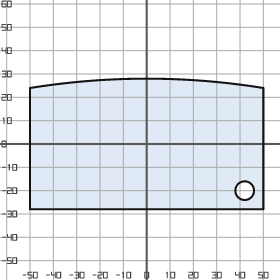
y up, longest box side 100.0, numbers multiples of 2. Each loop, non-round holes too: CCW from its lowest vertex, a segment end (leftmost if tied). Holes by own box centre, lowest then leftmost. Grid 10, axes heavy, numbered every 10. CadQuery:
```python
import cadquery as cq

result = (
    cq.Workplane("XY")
    .moveTo(-50.0, -28.0)
    .lineTo(50.0, -28.0)
    .lineTo(50.0, 24.0)
    .threePointArc((0.0, 28.0), (-50.0, 24.0))
    .close()
    .moveTo(42.0, -20.0)
    .circle(4.0)
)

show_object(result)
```